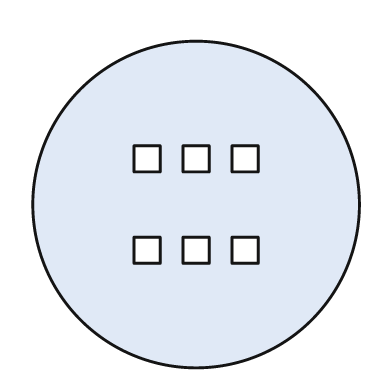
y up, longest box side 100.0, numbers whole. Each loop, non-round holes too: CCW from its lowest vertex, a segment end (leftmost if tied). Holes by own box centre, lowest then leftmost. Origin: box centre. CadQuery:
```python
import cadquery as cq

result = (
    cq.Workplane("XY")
    .moveTo(0.0, 0.0)
    .circle(50.0)
    .moveTo(-19.0, -18.0)
    .lineTo(-11.0, -18.0)
    .lineTo(-11.0, -10.0)
    .lineTo(-19.0, -10.0)
    .close()
    .moveTo(-4.0, -18.0)
    .lineTo(4.0, -18.0)
    .lineTo(4.0, -10.0)
    .lineTo(-4.0, -10.0)
    .close()
    .moveTo(11.0, -18.0)
    .lineTo(19.0, -18.0)
    .lineTo(19.0, -10.0)
    .lineTo(11.0, -10.0)
    .close()
    .moveTo(-19.0, 10.0)
    .lineTo(-11.0, 10.0)
    .lineTo(-11.0, 18.0)
    .lineTo(-19.0, 18.0)
    .close()
    .moveTo(-4.0, 10.0)
    .lineTo(4.0, 10.0)
    .lineTo(4.0, 18.0)
    .lineTo(-4.0, 18.0)
    .close()
    .moveTo(11.0, 10.0)
    .lineTo(19.0, 10.0)
    .lineTo(19.0, 18.0)
    .lineTo(11.0, 18.0)
    .close()
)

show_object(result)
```